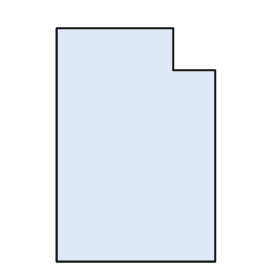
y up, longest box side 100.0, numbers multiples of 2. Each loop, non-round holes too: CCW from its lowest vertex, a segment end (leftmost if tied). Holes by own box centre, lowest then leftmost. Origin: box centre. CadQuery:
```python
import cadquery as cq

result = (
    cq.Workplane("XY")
    .moveTo(-34.0, -50.0)
    .lineTo(34.0, -50.0)
    .lineTo(34.0, 32.0)
    .lineTo(16.0, 32.0)
    .lineTo(16.0, 50.0)
    .lineTo(-34.0, 50.0)
    .close()
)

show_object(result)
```